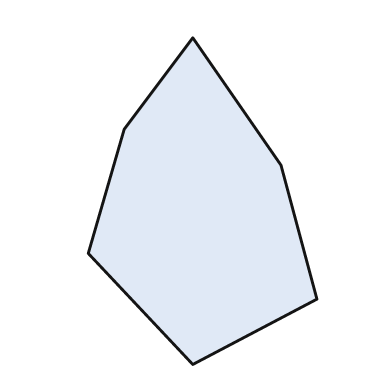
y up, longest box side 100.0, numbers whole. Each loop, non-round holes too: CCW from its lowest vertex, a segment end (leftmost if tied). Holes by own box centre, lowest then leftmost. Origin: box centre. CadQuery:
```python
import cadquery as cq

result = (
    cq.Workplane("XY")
    .moveTo(-3.0, -50.0)
    .lineTo(35.0, -30.0)
    .lineTo(24.0, 11.0)
    .lineTo(-3.0, 50.0)
    .lineTo(-24.0, 22.0)
    .lineTo(-35.0, -16.0)
    .close()
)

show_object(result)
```